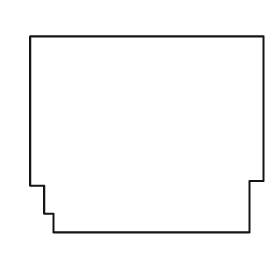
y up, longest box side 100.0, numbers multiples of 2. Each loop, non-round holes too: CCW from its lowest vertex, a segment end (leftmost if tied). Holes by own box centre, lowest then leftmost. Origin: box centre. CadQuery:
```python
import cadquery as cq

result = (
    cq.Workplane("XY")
    .moveTo(-40.0, -42.0)
    .lineTo(44.0, -42.0)
    .lineTo(44.0, -20.0)
    .lineTo(50.0, -20.0)
    .lineTo(50.0, 42.0)
    .lineTo(-50.0, 42.0)
    .lineTo(-50.0, -22.0)
    .lineTo(-44.0, -22.0)
    .lineTo(-44.0, -34.0)
    .lineTo(-40.0, -34.0)
    .close()
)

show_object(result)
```